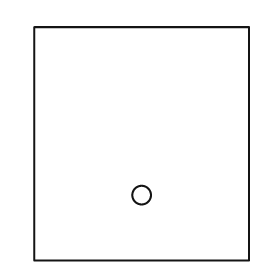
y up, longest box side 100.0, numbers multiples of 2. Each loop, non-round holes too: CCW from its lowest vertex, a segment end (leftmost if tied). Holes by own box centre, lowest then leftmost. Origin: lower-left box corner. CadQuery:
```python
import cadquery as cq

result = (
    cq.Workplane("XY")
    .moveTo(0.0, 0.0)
    .lineTo(92.0, 0.0)
    .lineTo(92.0, 100.0)
    .lineTo(0.0, 100.0)
    .close()
    .moveTo(46.0, 28.0)
    .circle(4.0)
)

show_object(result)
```